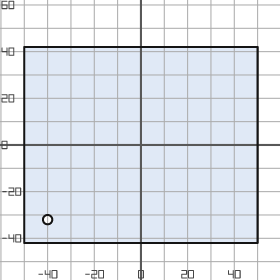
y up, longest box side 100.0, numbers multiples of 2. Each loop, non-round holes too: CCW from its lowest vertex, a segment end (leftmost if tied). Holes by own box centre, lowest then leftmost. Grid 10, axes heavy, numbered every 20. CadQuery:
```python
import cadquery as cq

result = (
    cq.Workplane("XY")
    .moveTo(-50.0, -42.0)
    .lineTo(50.0, -42.0)
    .lineTo(50.0, 42.0)
    .lineTo(-50.0, 42.0)
    .close()
    .moveTo(-40.0, -32.0)
    .circle(2.0)
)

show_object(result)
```